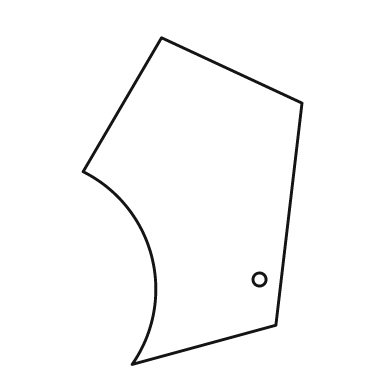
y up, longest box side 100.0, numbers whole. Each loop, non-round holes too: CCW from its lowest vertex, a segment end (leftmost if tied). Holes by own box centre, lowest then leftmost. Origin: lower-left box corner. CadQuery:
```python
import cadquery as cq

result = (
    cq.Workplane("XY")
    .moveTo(15.0, 0.0)
    .lineTo(59.0, 12.0)
    .lineTo(67.0, 80.0)
    .lineTo(24.0, 100.0)
    .lineTo(0.0, 59.0)
    .threePointArc((21.0, 33.0), (15.0, 0.0))
    .close()
    .moveTo(54.0, 26.0)
    .circle(2.0)
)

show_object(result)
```